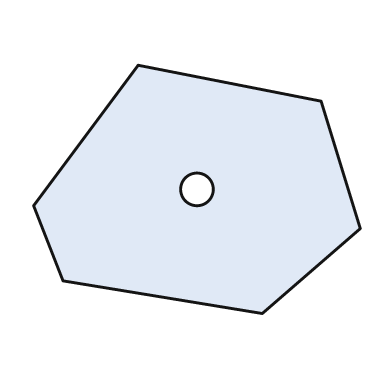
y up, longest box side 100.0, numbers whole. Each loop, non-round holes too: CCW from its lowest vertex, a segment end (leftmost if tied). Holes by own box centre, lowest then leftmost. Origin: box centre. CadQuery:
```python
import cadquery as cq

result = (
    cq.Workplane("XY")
    .moveTo(20.0, -38.0)
    .lineTo(50.0, -12.0)
    .lineTo(38.0, 27.0)
    .lineTo(-18.0, 38.0)
    .lineTo(-50.0, -5.0)
    .lineTo(-41.0, -28.0)
    .close()
    .moveTo(0.0, 0.0)
    .circle(5.0)
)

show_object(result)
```